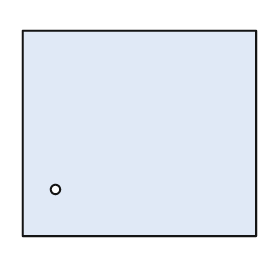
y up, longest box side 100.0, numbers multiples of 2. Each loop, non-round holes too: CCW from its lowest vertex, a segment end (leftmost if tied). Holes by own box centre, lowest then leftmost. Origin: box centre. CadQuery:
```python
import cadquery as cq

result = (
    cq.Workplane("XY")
    .moveTo(-50.0, -44.0)
    .lineTo(50.0, -44.0)
    .lineTo(50.0, 44.0)
    .lineTo(-50.0, 44.0)
    .close()
    .moveTo(-36.0, -24.0)
    .circle(2.0)
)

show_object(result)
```